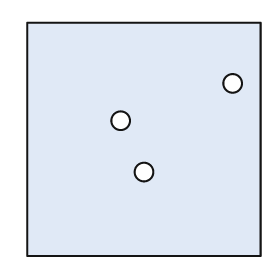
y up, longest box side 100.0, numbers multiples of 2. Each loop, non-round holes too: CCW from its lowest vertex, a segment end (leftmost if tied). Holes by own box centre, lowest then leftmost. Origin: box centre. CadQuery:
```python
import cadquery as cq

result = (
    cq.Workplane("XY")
    .moveTo(-50.0, -50.0)
    .lineTo(50.0, -50.0)
    .lineTo(50.0, 50.0)
    .lineTo(-50.0, 50.0)
    .close()
    .moveTo(0.0, -14.0)
    .circle(4.0)
    .moveTo(-10.0, 8.0)
    .circle(4.0)
    .moveTo(38.0, 24.0)
    .circle(4.0)
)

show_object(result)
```